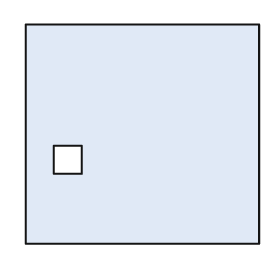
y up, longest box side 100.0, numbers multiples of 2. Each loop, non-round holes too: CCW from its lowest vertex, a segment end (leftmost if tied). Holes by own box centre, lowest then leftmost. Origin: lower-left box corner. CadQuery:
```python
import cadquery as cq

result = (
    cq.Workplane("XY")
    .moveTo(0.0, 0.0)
    .lineTo(100.0, 0.0)
    .lineTo(100.0, 94.0)
    .lineTo(0.0, 94.0)
    .close()
    .moveTo(12.0, 30.0)
    .lineTo(24.0, 30.0)
    .lineTo(24.0, 42.0)
    .lineTo(12.0, 42.0)
    .close()
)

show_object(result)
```